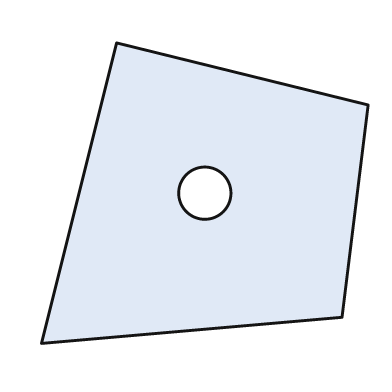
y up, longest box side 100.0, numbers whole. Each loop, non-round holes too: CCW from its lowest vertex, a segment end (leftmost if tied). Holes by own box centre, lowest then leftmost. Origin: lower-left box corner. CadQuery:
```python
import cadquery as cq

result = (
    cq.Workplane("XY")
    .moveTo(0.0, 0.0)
    .lineTo(92.0, 8.0)
    .lineTo(100.0, 73.0)
    .lineTo(23.0, 92.0)
    .close()
    .moveTo(50.0, 46.0)
    .circle(8.0)
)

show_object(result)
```